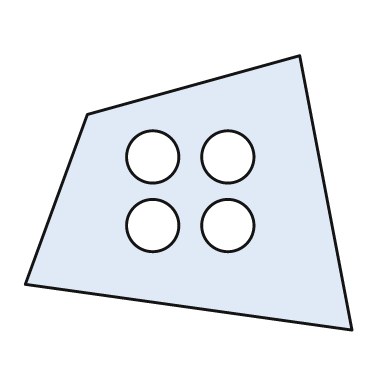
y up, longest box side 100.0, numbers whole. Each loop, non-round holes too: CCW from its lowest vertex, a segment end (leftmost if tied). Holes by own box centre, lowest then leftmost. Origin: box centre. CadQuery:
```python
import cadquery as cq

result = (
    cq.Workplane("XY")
    .moveTo(50.0, -42.0)
    .lineTo(34.0, 42.0)
    .lineTo(-31.0, 24.0)
    .lineTo(-50.0, -28.0)
    .close()
    .moveTo(-11.0, -10.0)
    .circle(8.0)
    .moveTo(12.0, -10.0)
    .circle(8.0)
    .moveTo(-11.0, 11.0)
    .circle(8.0)
    .moveTo(12.0, 11.0)
    .circle(8.0)
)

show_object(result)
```